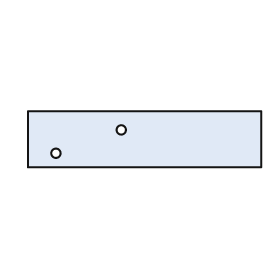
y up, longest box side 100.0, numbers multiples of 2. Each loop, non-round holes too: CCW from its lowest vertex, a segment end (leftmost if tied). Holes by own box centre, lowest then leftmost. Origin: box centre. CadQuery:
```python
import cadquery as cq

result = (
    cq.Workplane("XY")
    .moveTo(-50.0, -12.0)
    .lineTo(50.0, -12.0)
    .lineTo(50.0, 12.0)
    .lineTo(-50.0, 12.0)
    .close()
    .moveTo(-38.0, -6.0)
    .circle(2.0)
    .moveTo(-10.0, 4.0)
    .circle(2.0)
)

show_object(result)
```